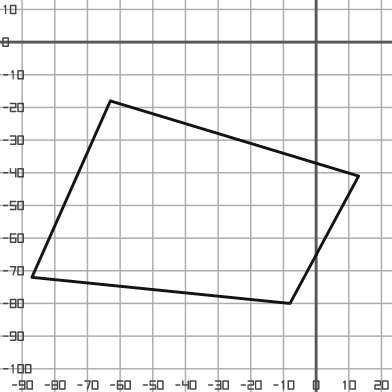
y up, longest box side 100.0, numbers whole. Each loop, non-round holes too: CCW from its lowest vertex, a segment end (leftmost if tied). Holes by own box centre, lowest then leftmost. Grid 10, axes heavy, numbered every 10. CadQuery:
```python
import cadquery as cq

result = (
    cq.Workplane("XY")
    .moveTo(-8.0, -80.0)
    .lineTo(13.0, -41.0)
    .lineTo(-63.0, -18.0)
    .lineTo(-87.0, -72.0)
    .close()
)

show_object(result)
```